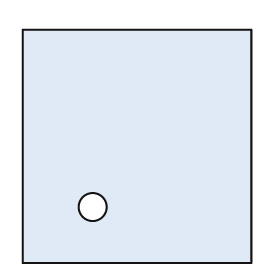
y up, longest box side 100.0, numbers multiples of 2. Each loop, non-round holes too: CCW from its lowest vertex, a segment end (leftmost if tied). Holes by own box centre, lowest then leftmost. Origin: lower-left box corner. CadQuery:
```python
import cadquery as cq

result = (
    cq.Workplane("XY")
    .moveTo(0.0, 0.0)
    .lineTo(98.0, 0.0)
    .lineTo(98.0, 100.0)
    .lineTo(0.0, 100.0)
    .close()
    .moveTo(30.0, 24.0)
    .circle(6.0)
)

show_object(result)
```